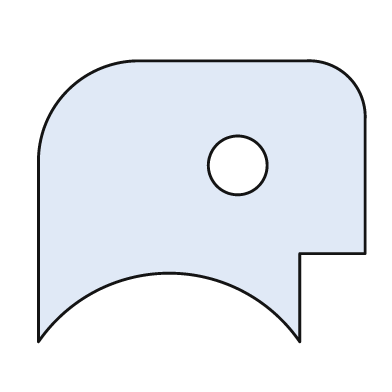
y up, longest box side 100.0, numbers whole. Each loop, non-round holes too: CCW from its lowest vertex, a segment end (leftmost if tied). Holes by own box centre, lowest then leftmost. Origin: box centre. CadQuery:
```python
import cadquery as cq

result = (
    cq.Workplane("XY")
    .moveTo(-50.0, -43.0)
    .threePointArc((-10.0, -22.0), (30.0, -43.0))
    .lineTo(30.0, -16.0)
    .lineTo(50.0, -16.0)
    .lineTo(50.0, 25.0)
    .threePointArc((45.0, 38.0), (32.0, 43.0))
    .lineTo(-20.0, 43.0)
    .threePointArc((-41.0, 34.0), (-50.0, 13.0))
    .close()
    .moveTo(11.0, 11.0)
    .circle(9.0)
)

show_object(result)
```